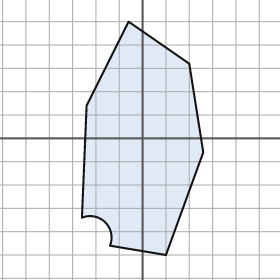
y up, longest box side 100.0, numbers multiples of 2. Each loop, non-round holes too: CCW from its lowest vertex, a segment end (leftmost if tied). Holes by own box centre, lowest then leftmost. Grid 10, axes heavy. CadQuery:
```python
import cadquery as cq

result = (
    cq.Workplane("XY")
    .moveTo(10.0, -50.0)
    .lineTo(26.0, -6.0)
    .lineTo(20.0, 32.0)
    .lineTo(-6.0, 50.0)
    .lineTo(-24.0, 14.0)
    .lineTo(-26.0, -34.0)
    .threePointArc((-16.0, -36.0), (-14.0, -46.0))
    .close()
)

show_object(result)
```